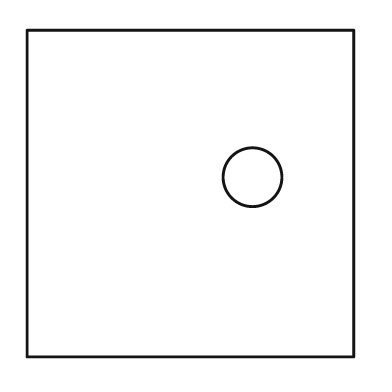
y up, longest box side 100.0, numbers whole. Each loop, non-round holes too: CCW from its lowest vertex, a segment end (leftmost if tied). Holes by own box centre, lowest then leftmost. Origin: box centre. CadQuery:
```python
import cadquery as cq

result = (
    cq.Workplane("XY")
    .moveTo(-50.0, -50.0)
    .lineTo(50.0, -50.0)
    .lineTo(50.0, 50.0)
    .lineTo(-50.0, 50.0)
    .close()
    .moveTo(19.0, 5.0)
    .circle(9.0)
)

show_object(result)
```